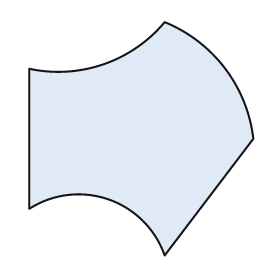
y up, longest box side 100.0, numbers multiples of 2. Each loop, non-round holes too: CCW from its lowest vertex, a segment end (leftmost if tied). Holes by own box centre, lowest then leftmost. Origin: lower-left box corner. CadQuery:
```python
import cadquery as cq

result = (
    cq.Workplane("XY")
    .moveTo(58.0, 0.0)
    .lineTo(96.0, 50.0)
    .threePointArc((84.0, 80.0), (58.0, 100.0))
    .threePointArc((32.0, 82.0), (0.0, 80.0))
    .lineTo(0.0, 20.0)
    .threePointArc((34.0, 24.0), (58.0, 0.0))
    .close()
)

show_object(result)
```